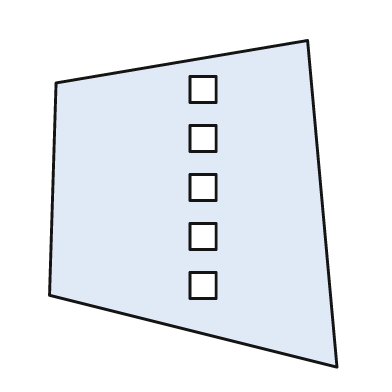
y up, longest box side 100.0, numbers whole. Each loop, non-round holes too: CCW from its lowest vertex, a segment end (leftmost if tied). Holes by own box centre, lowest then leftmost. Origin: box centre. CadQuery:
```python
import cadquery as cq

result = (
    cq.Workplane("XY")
    .moveTo(44.0, -50.0)
    .lineTo(35.0, 50.0)
    .lineTo(-42.0, 37.0)
    .lineTo(-44.0, -28.0)
    .close()
    .moveTo(-1.0, -29.0)
    .lineTo(7.0, -29.0)
    .lineTo(7.0, -21.0)
    .lineTo(-1.0, -21.0)
    .close()
    .moveTo(-1.0, -14.0)
    .lineTo(7.0, -14.0)
    .lineTo(7.0, -6.0)
    .lineTo(-1.0, -6.0)
    .close()
    .moveTo(-1.0, 1.0)
    .lineTo(7.0, 1.0)
    .lineTo(7.0, 9.0)
    .lineTo(-1.0, 9.0)
    .close()
    .moveTo(-1.0, 16.0)
    .lineTo(7.0, 16.0)
    .lineTo(7.0, 24.0)
    .lineTo(-1.0, 24.0)
    .close()
    .moveTo(-1.0, 31.0)
    .lineTo(7.0, 31.0)
    .lineTo(7.0, 39.0)
    .lineTo(-1.0, 39.0)
    .close()
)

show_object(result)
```